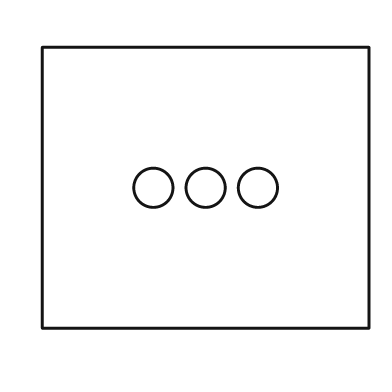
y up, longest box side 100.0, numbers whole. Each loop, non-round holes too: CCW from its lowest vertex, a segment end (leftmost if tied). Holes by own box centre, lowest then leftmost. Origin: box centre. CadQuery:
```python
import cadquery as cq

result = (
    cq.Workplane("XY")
    .moveTo(-50.0, -43.0)
    .lineTo(50.0, -43.0)
    .lineTo(50.0, 43.0)
    .lineTo(-50.0, 43.0)
    .close()
    .moveTo(-16.0, 0.0)
    .circle(6.0)
    .moveTo(0.0, 0.0)
    .circle(6.0)
    .moveTo(16.0, 0.0)
    .circle(6.0)
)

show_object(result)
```